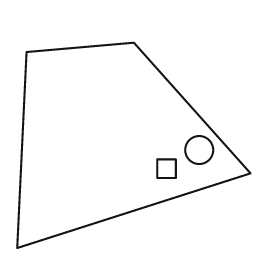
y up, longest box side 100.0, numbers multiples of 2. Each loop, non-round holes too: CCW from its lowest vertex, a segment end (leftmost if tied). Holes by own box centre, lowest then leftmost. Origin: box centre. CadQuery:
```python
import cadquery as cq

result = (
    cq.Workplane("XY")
    .moveTo(-50.0, -44.0)
    .lineTo(50.0, -12.0)
    .lineTo(0.0, 44.0)
    .lineTo(-46.0, 40.0)
    .close()
    .moveTo(10.0, -14.0)
    .lineTo(18.0, -14.0)
    .lineTo(18.0, -6.0)
    .lineTo(10.0, -6.0)
    .close()
    .moveTo(28.0, -2.0)
    .circle(6.0)
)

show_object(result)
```